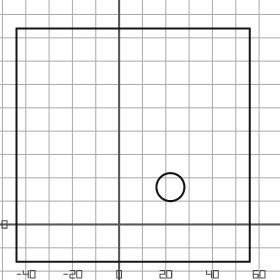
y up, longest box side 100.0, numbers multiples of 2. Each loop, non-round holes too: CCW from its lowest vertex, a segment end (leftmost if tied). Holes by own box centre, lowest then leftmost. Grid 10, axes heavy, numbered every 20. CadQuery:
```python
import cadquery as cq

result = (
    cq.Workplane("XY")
    .moveTo(-44.0, -16.0)
    .lineTo(56.0, -16.0)
    .lineTo(56.0, 84.0)
    .lineTo(-44.0, 84.0)
    .close()
    .moveTo(22.0, 16.0)
    .circle(6.0)
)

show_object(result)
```